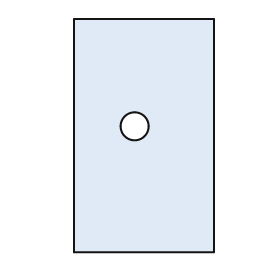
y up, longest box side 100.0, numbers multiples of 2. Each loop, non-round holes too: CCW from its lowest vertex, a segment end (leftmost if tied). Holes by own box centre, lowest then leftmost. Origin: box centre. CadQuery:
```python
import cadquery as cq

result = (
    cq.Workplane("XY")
    .moveTo(-30.0, -50.0)
    .lineTo(30.0, -50.0)
    .lineTo(30.0, 50.0)
    .lineTo(-30.0, 50.0)
    .close()
    .moveTo(-4.0, 4.0)
    .circle(6.0)
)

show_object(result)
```